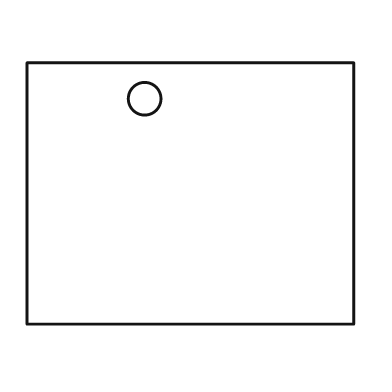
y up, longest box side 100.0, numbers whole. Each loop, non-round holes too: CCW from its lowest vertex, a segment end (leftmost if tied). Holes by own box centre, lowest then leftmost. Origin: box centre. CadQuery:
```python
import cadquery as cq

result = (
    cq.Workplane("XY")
    .moveTo(-50.0, -40.0)
    .lineTo(50.0, -40.0)
    .lineTo(50.0, 40.0)
    .lineTo(-50.0, 40.0)
    .close()
    .moveTo(-14.0, 29.0)
    .circle(5.0)
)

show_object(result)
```